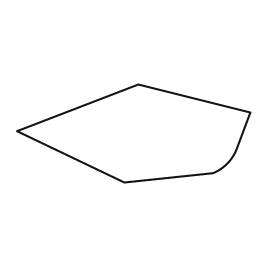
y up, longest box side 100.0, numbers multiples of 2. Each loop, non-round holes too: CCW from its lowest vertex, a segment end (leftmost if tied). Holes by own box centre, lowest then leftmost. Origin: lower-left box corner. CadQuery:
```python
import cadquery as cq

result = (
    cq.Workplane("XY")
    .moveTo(46.0, 0.0)
    .lineTo(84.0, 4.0)
    .threePointArc((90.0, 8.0), (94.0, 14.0))
    .lineTo(100.0, 30.0)
    .lineTo(52.0, 42.0)
    .lineTo(0.0, 22.0)
    .close()
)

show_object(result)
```